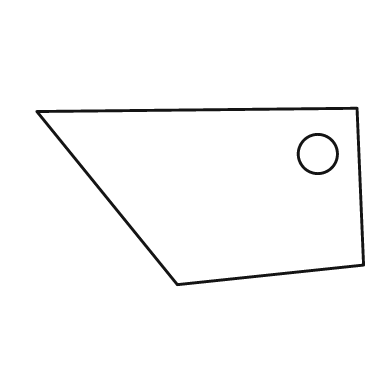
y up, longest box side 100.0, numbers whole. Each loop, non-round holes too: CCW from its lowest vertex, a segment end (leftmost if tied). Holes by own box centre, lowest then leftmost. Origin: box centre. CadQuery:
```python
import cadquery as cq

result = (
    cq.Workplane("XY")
    .moveTo(-7.0, -27.0)
    .lineTo(50.0, -21.0)
    .lineTo(48.0, 27.0)
    .lineTo(-50.0, 26.0)
    .close()
    .moveTo(36.0, 13.0)
    .circle(6.0)
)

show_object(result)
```